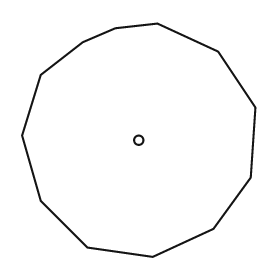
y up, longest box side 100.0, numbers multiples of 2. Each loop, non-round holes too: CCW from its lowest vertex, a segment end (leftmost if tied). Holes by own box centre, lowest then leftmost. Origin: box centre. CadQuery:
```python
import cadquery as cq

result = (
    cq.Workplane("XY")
    .moveTo(6.0, -50.0)
    .lineTo(32.0, -38.0)
    .lineTo(48.0, -16.0)
    .lineTo(50.0, 14.0)
    .lineTo(34.0, 38.0)
    .lineTo(8.0, 50.0)
    .lineTo(-10.0, 48.0)
    .lineTo(-24.0, 42.0)
    .lineTo(-42.0, 28.0)
    .lineTo(-50.0, 2.0)
    .lineTo(-42.0, -26.0)
    .lineTo(-22.0, -46.0)
    .close()
    .moveTo(0.0, 0.0)
    .circle(2.0)
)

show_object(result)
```